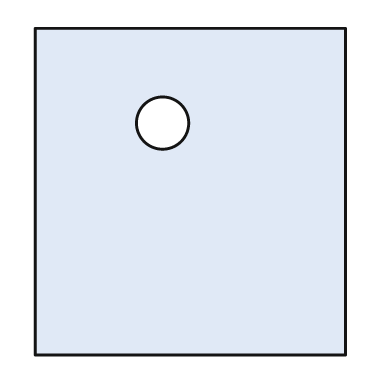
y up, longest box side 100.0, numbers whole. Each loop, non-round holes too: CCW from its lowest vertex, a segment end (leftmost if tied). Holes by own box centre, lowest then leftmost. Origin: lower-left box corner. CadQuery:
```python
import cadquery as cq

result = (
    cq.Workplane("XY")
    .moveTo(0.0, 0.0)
    .lineTo(95.0, 0.0)
    .lineTo(95.0, 100.0)
    .lineTo(0.0, 100.0)
    .close()
    .moveTo(39.0, 71.0)
    .circle(8.0)
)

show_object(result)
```